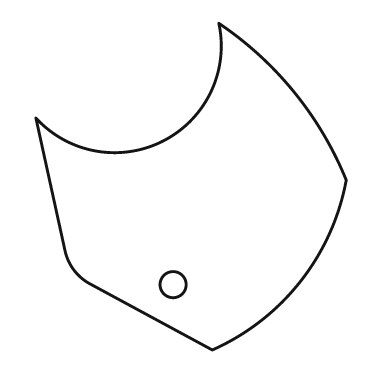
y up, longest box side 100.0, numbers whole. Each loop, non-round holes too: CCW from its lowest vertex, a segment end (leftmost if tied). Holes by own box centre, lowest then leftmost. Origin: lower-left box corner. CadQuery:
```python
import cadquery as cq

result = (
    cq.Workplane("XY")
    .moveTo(54.0, 0.0)
    .threePointArc((81.0, 21.0), (95.0, 52.0))
    .threePointArc((79.0, 79.0), (56.0, 100.0))
    .threePointArc((39.0, 64.0), (0.0, 71.0))
    .lineTo(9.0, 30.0)
    .threePointArc((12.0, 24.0), (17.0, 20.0))
    .close()
    .moveTo(42.0, 20.0)
    .circle(4.0)
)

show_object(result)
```